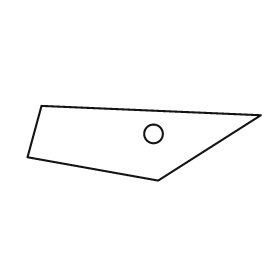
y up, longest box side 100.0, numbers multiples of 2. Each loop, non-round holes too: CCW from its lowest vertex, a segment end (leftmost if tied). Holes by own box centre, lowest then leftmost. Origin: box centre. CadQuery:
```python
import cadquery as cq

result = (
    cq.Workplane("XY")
    .moveTo(6.0, -16.0)
    .lineTo(50.0, 12.0)
    .lineTo(-44.0, 16.0)
    .lineTo(-50.0, -6.0)
    .close()
    .moveTo(4.0, 4.0)
    .circle(4.0)
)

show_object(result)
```